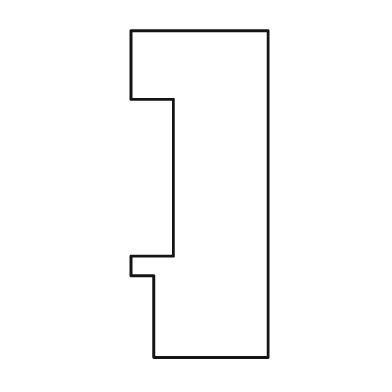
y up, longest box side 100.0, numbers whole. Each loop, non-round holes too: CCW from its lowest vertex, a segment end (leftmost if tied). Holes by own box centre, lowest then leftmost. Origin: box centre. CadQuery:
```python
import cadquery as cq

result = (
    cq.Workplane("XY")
    .moveTo(-14.0, -50.0)
    .lineTo(21.0, -50.0)
    .lineTo(21.0, 50.0)
    .lineTo(-21.0, 50.0)
    .lineTo(-21.0, 29.0)
    .lineTo(-8.0, 29.0)
    .lineTo(-8.0, -19.0)
    .lineTo(-21.0, -19.0)
    .lineTo(-21.0, -25.0)
    .lineTo(-14.0, -25.0)
    .close()
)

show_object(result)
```